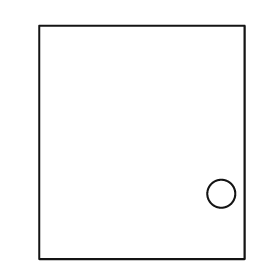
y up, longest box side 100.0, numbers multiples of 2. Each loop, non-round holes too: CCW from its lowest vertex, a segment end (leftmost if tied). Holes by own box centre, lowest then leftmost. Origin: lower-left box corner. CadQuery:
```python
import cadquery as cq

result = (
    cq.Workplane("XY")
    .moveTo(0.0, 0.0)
    .lineTo(88.0, 0.0)
    .lineTo(88.0, 100.0)
    .lineTo(0.0, 100.0)
    .close()
    .moveTo(78.0, 28.0)
    .circle(6.0)
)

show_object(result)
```